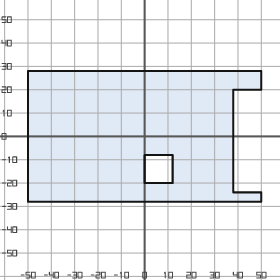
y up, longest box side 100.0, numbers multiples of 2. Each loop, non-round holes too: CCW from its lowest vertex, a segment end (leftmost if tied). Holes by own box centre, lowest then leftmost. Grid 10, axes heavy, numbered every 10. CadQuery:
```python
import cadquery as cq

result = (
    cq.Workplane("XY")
    .moveTo(-50.0, -28.0)
    .lineTo(50.0, -28.0)
    .lineTo(50.0, -24.0)
    .lineTo(38.0, -24.0)
    .lineTo(38.0, 20.0)
    .lineTo(50.0, 20.0)
    .lineTo(50.0, 28.0)
    .lineTo(-50.0, 28.0)
    .close()
    .moveTo(0.0, -20.0)
    .lineTo(12.0, -20.0)
    .lineTo(12.0, -8.0)
    .lineTo(0.0, -8.0)
    .close()
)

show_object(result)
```